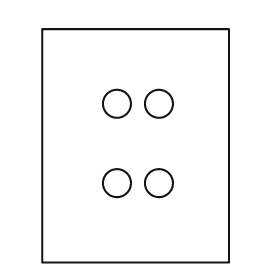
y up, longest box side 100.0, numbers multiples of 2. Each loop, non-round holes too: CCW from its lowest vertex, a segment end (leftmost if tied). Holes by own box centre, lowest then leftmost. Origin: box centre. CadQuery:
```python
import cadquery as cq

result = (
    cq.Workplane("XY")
    .moveTo(-40.0, -50.0)
    .lineTo(40.0, -50.0)
    .lineTo(40.0, 50.0)
    .lineTo(-40.0, 50.0)
    .close()
    .moveTo(-8.0, -16.0)
    .circle(6.0)
    .moveTo(10.0, -16.0)
    .circle(6.0)
    .moveTo(-8.0, 18.0)
    .circle(6.0)
    .moveTo(10.0, 18.0)
    .circle(6.0)
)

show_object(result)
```